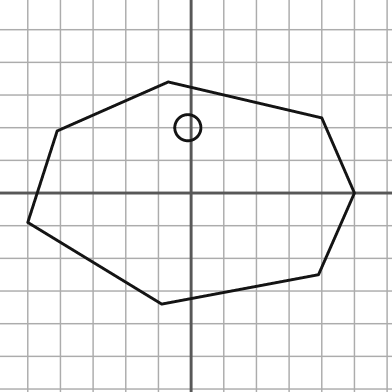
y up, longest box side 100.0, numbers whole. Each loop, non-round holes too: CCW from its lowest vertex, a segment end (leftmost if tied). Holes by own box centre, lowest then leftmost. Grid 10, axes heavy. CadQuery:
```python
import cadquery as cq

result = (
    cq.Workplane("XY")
    .moveTo(-9.0, -34.0)
    .lineTo(39.0, -25.0)
    .lineTo(50.0, 0.0)
    .lineTo(40.0, 23.0)
    .lineTo(-7.0, 34.0)
    .lineTo(-41.0, 19.0)
    .lineTo(-50.0, -9.0)
    .close()
    .moveTo(-1.0, 20.0)
    .circle(4.0)
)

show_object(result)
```